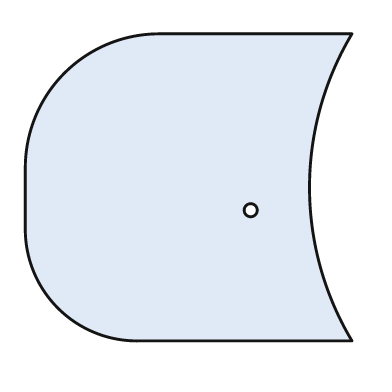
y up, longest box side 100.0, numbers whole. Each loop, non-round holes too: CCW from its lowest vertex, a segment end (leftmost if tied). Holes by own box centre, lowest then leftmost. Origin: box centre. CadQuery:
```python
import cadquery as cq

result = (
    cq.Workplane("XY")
    .moveTo(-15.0, -47.0)
    .lineTo(50.0, -47.0)
    .threePointArc((37.0, 0.0), (50.0, 47.0))
    .lineTo(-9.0, 47.0)
    .threePointArc((-38.0, 35.0), (-50.0, 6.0))
    .lineTo(-50.0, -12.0)
    .threePointArc((-40.0, -37.0), (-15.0, -47.0))
    .close()
    .moveTo(19.0, -7.0)
    .circle(2.0)
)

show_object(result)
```